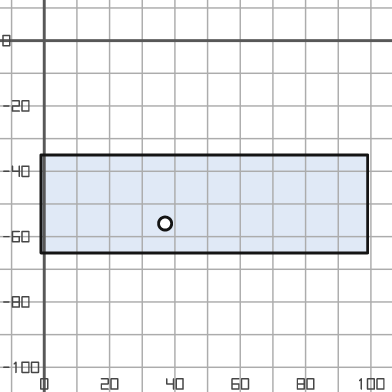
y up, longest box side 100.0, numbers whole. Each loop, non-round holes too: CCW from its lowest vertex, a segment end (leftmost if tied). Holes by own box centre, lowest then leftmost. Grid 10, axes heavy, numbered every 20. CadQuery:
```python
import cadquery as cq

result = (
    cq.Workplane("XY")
    .moveTo(-1.0, -65.0)
    .lineTo(99.0, -65.0)
    .lineTo(99.0, -35.0)
    .lineTo(-1.0, -35.0)
    .close()
    .moveTo(37.0, -56.0)
    .circle(2.0)
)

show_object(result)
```